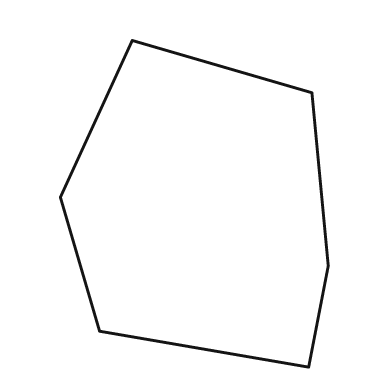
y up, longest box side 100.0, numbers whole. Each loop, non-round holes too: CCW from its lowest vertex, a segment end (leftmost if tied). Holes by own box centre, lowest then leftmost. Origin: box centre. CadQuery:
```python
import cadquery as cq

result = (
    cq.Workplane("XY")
    .moveTo(35.0, -50.0)
    .lineTo(41.0, -19.0)
    .lineTo(36.0, 34.0)
    .lineTo(-19.0, 50.0)
    .lineTo(-41.0, 2.0)
    .lineTo(-29.0, -39.0)
    .close()
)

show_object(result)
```